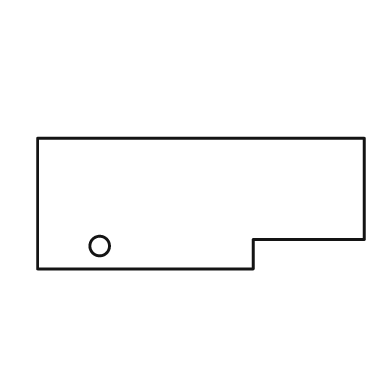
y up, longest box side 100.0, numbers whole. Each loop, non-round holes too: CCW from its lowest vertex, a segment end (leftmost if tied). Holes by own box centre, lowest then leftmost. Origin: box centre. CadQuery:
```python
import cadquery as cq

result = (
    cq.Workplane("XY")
    .moveTo(-50.0, -20.0)
    .lineTo(16.0, -20.0)
    .lineTo(16.0, -11.0)
    .lineTo(50.0, -11.0)
    .lineTo(50.0, 20.0)
    .lineTo(-50.0, 20.0)
    .close()
    .moveTo(-31.0, -13.0)
    .circle(3.0)
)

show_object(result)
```